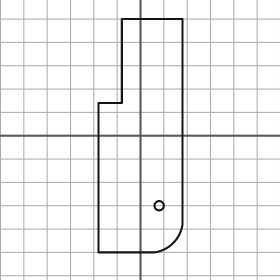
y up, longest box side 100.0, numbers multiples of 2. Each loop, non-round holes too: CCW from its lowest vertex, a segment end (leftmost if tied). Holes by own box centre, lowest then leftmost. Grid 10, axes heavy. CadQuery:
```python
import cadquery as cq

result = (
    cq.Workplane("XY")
    .moveTo(-18.0, -50.0)
    .lineTo(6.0, -50.0)
    .threePointArc((14.0, -46.0), (18.0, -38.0))
    .lineTo(18.0, 50.0)
    .lineTo(-8.0, 50.0)
    .lineTo(-8.0, 14.0)
    .lineTo(-18.0, 14.0)
    .close()
    .moveTo(8.0, -30.0)
    .circle(2.0)
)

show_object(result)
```